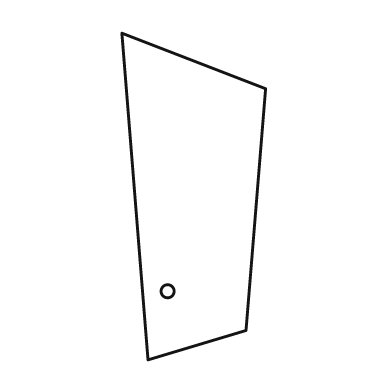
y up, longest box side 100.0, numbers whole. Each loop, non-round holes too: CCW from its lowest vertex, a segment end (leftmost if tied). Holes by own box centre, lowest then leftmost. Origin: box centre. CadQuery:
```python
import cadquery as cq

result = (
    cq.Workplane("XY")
    .moveTo(-14.0, -50.0)
    .lineTo(16.0, -41.0)
    .lineTo(22.0, 33.0)
    .lineTo(-22.0, 50.0)
    .close()
    .moveTo(-8.0, -29.0)
    .circle(2.0)
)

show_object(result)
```